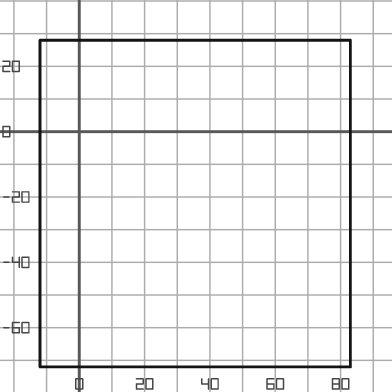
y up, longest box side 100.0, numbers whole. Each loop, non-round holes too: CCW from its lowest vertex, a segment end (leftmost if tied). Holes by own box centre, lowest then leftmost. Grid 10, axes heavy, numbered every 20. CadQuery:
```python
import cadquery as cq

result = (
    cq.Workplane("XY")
    .moveTo(-12.0, -72.0)
    .lineTo(83.0, -72.0)
    .lineTo(83.0, 28.0)
    .lineTo(-12.0, 28.0)
    .close()
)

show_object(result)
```